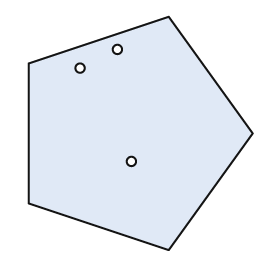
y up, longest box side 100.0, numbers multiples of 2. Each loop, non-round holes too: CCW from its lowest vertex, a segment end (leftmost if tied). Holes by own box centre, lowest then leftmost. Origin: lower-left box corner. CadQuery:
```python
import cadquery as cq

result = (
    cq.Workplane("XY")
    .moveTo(60.0, 0.0)
    .lineTo(96.0, 50.0)
    .lineTo(60.0, 100.0)
    .lineTo(0.0, 80.0)
    .lineTo(0.0, 20.0)
    .close()
    .moveTo(44.0, 38.0)
    .circle(2.0)
    .moveTo(22.0, 78.0)
    .circle(2.0)
    .moveTo(38.0, 86.0)
    .circle(2.0)
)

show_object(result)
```